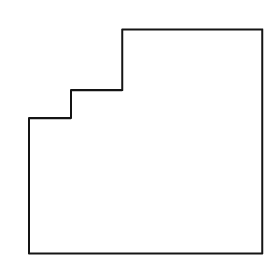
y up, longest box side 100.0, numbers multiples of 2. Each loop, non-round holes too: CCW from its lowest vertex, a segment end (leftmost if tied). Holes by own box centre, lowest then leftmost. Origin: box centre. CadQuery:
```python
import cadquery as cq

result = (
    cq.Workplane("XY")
    .moveTo(-50.0, -48.0)
    .lineTo(50.0, -48.0)
    .lineTo(50.0, 48.0)
    .lineTo(-10.0, 48.0)
    .lineTo(-10.0, 22.0)
    .lineTo(-32.0, 22.0)
    .lineTo(-32.0, 10.0)
    .lineTo(-50.0, 10.0)
    .close()
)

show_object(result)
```